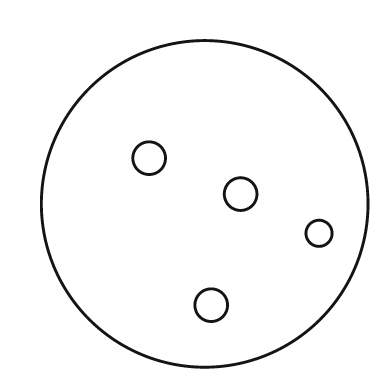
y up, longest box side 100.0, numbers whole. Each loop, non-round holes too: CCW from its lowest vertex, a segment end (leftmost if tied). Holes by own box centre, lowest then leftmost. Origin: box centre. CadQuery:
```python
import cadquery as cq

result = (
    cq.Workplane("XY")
    .moveTo(0.0, 0.0)
    .circle(50.0)
    .moveTo(2.0, -31.0)
    .circle(5.0)
    .moveTo(35.0, -9.0)
    .circle(4.0)
    .moveTo(11.0, 3.0)
    .circle(5.0)
    .moveTo(-17.0, 14.0)
    .circle(5.0)
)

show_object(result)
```